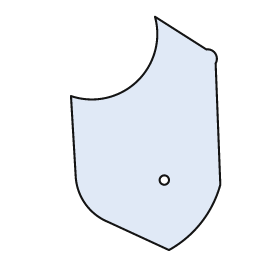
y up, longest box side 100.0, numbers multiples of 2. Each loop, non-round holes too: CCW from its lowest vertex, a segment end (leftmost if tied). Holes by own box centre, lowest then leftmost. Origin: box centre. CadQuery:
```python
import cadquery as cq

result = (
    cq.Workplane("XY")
    .moveTo(10.0, -50.0)
    .threePointArc((24.0, -38.0), (32.0, -22.0))
    .lineTo(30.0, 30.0)
    .threePointArc((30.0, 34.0), (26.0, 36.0))
    .lineTo(4.0, 50.0)
    .threePointArc((-4.0, 22.0), (-32.0, 16.0))
    .lineTo(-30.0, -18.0)
    .threePointArc((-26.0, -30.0), (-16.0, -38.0))
    .close()
    .moveTo(8.0, -20.0)
    .circle(2.0)
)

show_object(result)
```